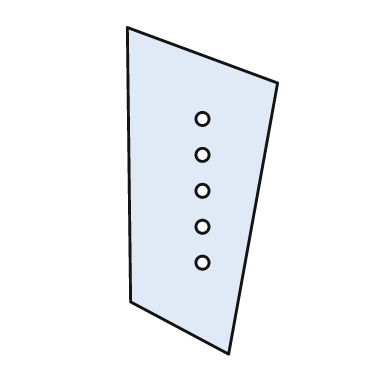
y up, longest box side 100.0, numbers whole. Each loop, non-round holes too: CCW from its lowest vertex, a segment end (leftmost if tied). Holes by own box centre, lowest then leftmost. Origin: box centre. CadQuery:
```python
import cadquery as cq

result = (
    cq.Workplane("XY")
    .moveTo(8.0, -50.0)
    .lineTo(23.0, 33.0)
    .lineTo(-23.0, 50.0)
    .lineTo(-22.0, -34.0)
    .close()
    .moveTo(0.0, -22.0)
    .circle(2.0)
    .moveTo(0.0, -11.0)
    .circle(2.0)
    .moveTo(0.0, 0.0)
    .circle(2.0)
    .moveTo(0.0, 11.0)
    .circle(2.0)
    .moveTo(0.0, 22.0)
    .circle(2.0)
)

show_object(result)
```